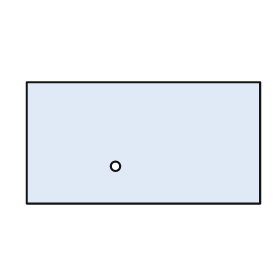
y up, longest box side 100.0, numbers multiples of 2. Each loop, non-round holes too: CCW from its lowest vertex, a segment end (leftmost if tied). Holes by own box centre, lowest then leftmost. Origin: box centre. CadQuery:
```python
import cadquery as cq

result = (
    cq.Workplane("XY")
    .moveTo(-50.0, -26.0)
    .lineTo(50.0, -26.0)
    .lineTo(50.0, 26.0)
    .lineTo(-50.0, 26.0)
    .close()
    .moveTo(-12.0, -10.0)
    .circle(2.0)
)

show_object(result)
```